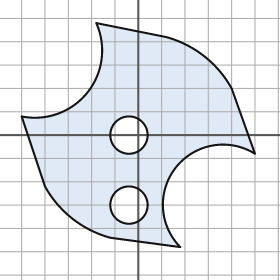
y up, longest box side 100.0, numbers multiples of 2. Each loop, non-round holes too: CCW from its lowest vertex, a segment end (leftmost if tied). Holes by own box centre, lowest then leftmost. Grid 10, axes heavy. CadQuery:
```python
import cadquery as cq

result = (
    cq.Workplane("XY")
    .moveTo(18.0, -48.0)
    .threePointArc((16.0, -14.0), (50.0, -8.0))
    .lineTo(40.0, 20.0)
    .threePointArc((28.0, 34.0), (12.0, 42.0))
    .lineTo(-18.0, 48.0)
    .threePointArc((-22.0, 18.0), (-50.0, 8.0))
    .lineTo(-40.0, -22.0)
    .threePointArc((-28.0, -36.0), (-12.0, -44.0))
    .close()
    .moveTo(-4.0, -30.0)
    .circle(8.0)
    .moveTo(-4.0, 0.0)
    .circle(8.0)
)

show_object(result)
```